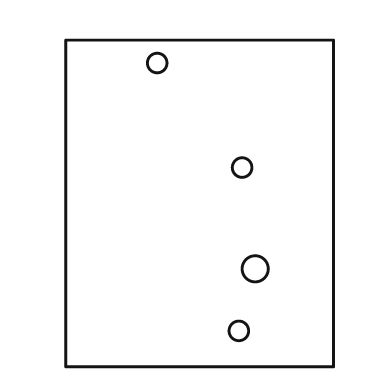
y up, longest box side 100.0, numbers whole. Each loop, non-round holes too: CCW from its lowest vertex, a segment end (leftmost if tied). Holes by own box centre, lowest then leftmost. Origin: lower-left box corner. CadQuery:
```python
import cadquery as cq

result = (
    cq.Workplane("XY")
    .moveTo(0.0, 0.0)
    .lineTo(82.0, 0.0)
    .lineTo(82.0, 100.0)
    .lineTo(0.0, 100.0)
    .close()
    .moveTo(53.0, 11.0)
    .circle(3.0)
    .moveTo(58.0, 30.0)
    .circle(4.0)
    .moveTo(54.0, 61.0)
    .circle(3.0)
    .moveTo(28.0, 93.0)
    .circle(3.0)
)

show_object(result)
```